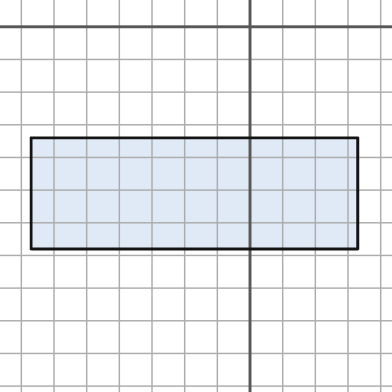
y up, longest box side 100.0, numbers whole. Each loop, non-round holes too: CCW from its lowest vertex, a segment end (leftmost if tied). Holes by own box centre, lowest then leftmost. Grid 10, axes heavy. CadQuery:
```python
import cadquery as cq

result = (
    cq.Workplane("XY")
    .moveTo(-67.0, -68.0)
    .lineTo(33.0, -68.0)
    .lineTo(33.0, -34.0)
    .lineTo(-67.0, -34.0)
    .close()
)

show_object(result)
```